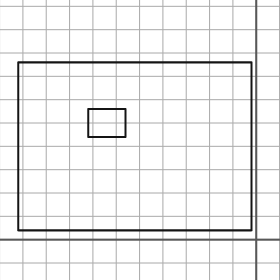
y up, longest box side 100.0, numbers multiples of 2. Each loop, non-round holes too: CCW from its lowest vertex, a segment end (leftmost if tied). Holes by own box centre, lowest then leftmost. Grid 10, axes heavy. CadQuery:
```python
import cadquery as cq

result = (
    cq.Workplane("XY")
    .moveTo(-102.0, 4.0)
    .lineTo(-2.0, 4.0)
    .lineTo(-2.0, 76.0)
    .lineTo(-102.0, 76.0)
    .close()
    .moveTo(-72.0, 44.0)
    .lineTo(-56.0, 44.0)
    .lineTo(-56.0, 56.0)
    .lineTo(-72.0, 56.0)
    .close()
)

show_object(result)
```